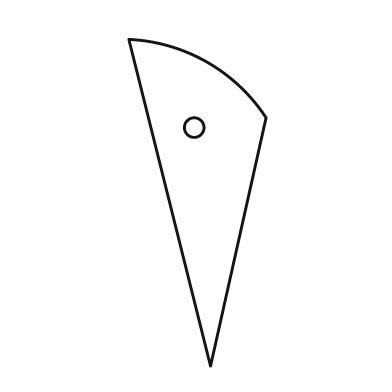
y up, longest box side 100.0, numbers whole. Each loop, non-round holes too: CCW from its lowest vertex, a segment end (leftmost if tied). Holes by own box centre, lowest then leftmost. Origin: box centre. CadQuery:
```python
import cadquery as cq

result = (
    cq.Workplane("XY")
    .moveTo(4.0, -50.0)
    .lineTo(21.0, 26.0)
    .threePointArc((3.0, 43.0), (-21.0, 50.0))
    .close()
    .moveTo(-1.0, 23.0)
    .circle(3.0)
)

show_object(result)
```